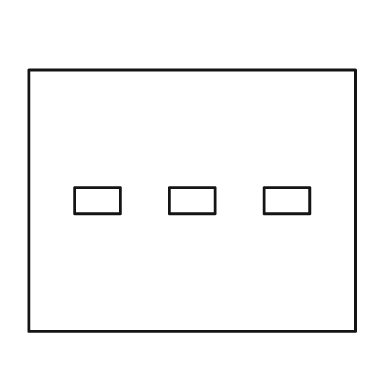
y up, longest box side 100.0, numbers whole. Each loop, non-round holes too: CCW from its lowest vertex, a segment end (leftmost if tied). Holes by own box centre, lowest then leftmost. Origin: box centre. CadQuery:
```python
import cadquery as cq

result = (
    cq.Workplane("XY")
    .moveTo(-50.0, -40.0)
    .lineTo(50.0, -40.0)
    .lineTo(50.0, 40.0)
    .lineTo(-50.0, 40.0)
    .close()
    .moveTo(-36.0, -4.0)
    .lineTo(-22.0, -4.0)
    .lineTo(-22.0, 4.0)
    .lineTo(-36.0, 4.0)
    .close()
    .moveTo(-7.0, -4.0)
    .lineTo(7.0, -4.0)
    .lineTo(7.0, 4.0)
    .lineTo(-7.0, 4.0)
    .close()
    .moveTo(22.0, -4.0)
    .lineTo(36.0, -4.0)
    .lineTo(36.0, 4.0)
    .lineTo(22.0, 4.0)
    .close()
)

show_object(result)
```